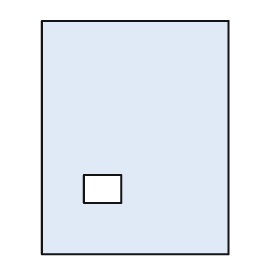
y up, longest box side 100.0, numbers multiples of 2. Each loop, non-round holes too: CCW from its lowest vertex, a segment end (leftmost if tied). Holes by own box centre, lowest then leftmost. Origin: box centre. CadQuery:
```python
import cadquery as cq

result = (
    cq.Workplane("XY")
    .moveTo(-40.0, -50.0)
    .lineTo(40.0, -50.0)
    .lineTo(40.0, 50.0)
    .lineTo(-40.0, 50.0)
    .close()
    .moveTo(-22.0, -28.0)
    .lineTo(-6.0, -28.0)
    .lineTo(-6.0, -16.0)
    .lineTo(-22.0, -16.0)
    .close()
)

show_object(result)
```